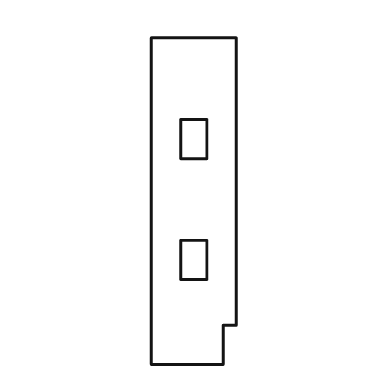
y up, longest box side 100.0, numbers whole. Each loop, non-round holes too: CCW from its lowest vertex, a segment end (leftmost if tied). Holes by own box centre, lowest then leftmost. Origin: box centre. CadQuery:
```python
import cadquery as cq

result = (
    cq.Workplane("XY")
    .moveTo(-13.0, -50.0)
    .lineTo(9.0, -50.0)
    .lineTo(9.0, -38.0)
    .lineTo(13.0, -38.0)
    .lineTo(13.0, 50.0)
    .lineTo(-13.0, 50.0)
    .close()
    .moveTo(-4.0, -24.0)
    .lineTo(4.0, -24.0)
    .lineTo(4.0, -12.0)
    .lineTo(-4.0, -12.0)
    .close()
    .moveTo(-4.0, 13.0)
    .lineTo(4.0, 13.0)
    .lineTo(4.0, 25.0)
    .lineTo(-4.0, 25.0)
    .close()
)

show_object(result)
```